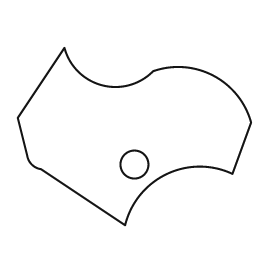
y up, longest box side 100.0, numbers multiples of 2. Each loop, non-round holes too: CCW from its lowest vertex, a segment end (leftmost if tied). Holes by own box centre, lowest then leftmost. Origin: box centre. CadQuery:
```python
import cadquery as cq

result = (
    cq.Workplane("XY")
    .moveTo(-4.0, -38.0)
    .threePointArc((14.0, -16.0), (42.0, -16.0))
    .lineTo(50.0, 6.0)
    .threePointArc((34.0, 26.0), (8.0, 28.0))
    .threePointArc((-14.0, 22.0), (-30.0, 38.0))
    .lineTo(-50.0, 8.0)
    .lineTo(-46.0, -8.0)
    .threePointArc((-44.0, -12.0), (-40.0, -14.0))
    .close()
    .moveTo(0.0, -12.0)
    .circle(6.0)
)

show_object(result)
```